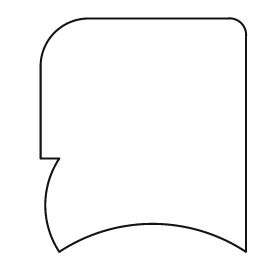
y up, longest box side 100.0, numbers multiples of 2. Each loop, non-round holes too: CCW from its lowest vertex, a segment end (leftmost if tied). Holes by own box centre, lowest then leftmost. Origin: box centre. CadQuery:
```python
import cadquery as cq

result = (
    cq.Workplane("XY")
    .moveTo(-36.0, -50.0)
    .threePointArc((4.0, -38.0), (44.0, -50.0))
    .lineTo(44.0, 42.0)
    .threePointArc((42.0, 48.0), (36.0, 50.0))
    .lineTo(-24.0, 50.0)
    .threePointArc((-38.0, 44.0), (-44.0, 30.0))
    .lineTo(-44.0, -10.0)
    .lineTo(-36.0, -10.0)
    .threePointArc((-42.0, -30.0), (-36.0, -50.0))
    .close()
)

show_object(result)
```